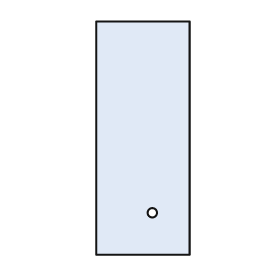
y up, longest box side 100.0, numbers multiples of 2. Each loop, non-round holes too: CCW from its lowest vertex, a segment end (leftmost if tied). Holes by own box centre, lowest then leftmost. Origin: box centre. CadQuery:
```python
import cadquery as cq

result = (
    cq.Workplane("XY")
    .moveTo(-20.0, -50.0)
    .lineTo(20.0, -50.0)
    .lineTo(20.0, 50.0)
    .lineTo(-20.0, 50.0)
    .close()
    .moveTo(4.0, -32.0)
    .circle(2.0)
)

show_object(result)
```